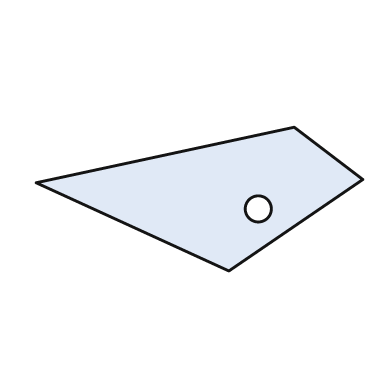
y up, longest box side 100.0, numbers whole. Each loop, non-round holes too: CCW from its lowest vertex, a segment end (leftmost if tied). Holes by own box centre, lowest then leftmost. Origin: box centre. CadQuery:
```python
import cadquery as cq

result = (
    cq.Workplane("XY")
    .moveTo(9.0, -22.0)
    .lineTo(50.0, 6.0)
    .lineTo(29.0, 22.0)
    .lineTo(-50.0, 5.0)
    .close()
    .moveTo(18.0, -3.0)
    .circle(4.0)
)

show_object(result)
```